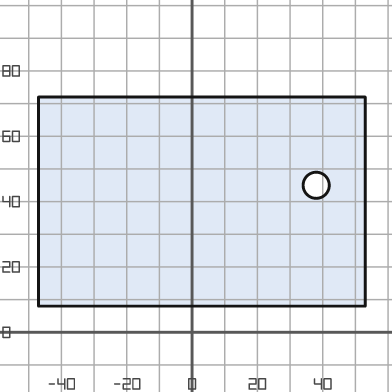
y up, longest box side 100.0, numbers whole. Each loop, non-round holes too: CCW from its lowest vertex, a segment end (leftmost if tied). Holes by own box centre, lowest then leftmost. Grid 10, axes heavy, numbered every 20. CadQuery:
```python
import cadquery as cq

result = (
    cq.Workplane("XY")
    .moveTo(-47.0, 8.0)
    .lineTo(53.0, 8.0)
    .lineTo(53.0, 72.0)
    .lineTo(-47.0, 72.0)
    .close()
    .moveTo(38.0, 45.0)
    .circle(4.0)
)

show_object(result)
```